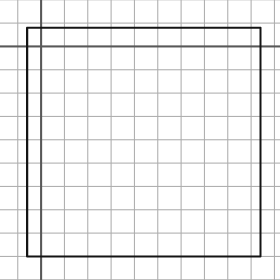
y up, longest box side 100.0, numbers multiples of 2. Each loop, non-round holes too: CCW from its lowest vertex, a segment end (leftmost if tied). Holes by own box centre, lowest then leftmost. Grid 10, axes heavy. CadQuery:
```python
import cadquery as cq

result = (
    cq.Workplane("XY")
    .moveTo(-6.0, -90.0)
    .lineTo(94.0, -90.0)
    .lineTo(94.0, 8.0)
    .lineTo(-6.0, 8.0)
    .close()
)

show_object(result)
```